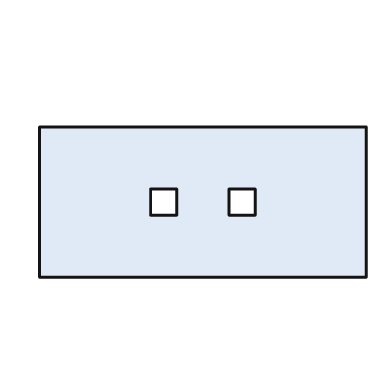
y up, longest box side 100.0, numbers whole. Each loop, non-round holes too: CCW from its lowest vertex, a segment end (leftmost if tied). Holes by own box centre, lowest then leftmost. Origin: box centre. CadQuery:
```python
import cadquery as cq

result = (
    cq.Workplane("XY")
    .moveTo(-50.0, -23.0)
    .lineTo(50.0, -23.0)
    .lineTo(50.0, 23.0)
    .lineTo(-50.0, 23.0)
    .close()
    .moveTo(-16.0, -4.0)
    .lineTo(-8.0, -4.0)
    .lineTo(-8.0, 4.0)
    .lineTo(-16.0, 4.0)
    .close()
    .moveTo(8.0, -4.0)
    .lineTo(16.0, -4.0)
    .lineTo(16.0, 4.0)
    .lineTo(8.0, 4.0)
    .close()
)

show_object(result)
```